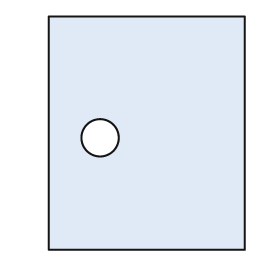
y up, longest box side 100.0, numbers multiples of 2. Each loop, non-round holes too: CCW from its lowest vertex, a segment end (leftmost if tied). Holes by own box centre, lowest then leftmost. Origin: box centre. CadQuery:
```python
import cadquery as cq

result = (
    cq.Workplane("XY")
    .moveTo(-42.0, -50.0)
    .lineTo(42.0, -50.0)
    .lineTo(42.0, 50.0)
    .lineTo(-42.0, 50.0)
    .close()
    .moveTo(-20.0, -2.0)
    .circle(8.0)
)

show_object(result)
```